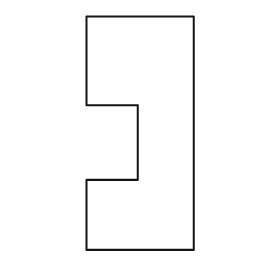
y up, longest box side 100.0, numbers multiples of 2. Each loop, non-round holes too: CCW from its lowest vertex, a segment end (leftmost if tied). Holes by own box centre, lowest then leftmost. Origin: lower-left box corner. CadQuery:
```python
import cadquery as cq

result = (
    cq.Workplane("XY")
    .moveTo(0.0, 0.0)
    .lineTo(46.0, 0.0)
    .lineTo(46.0, 100.0)
    .lineTo(0.0, 100.0)
    .lineTo(0.0, 62.0)
    .lineTo(22.0, 62.0)
    .lineTo(22.0, 30.0)
    .lineTo(0.0, 30.0)
    .close()
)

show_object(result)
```